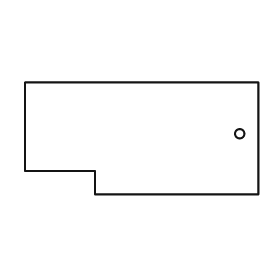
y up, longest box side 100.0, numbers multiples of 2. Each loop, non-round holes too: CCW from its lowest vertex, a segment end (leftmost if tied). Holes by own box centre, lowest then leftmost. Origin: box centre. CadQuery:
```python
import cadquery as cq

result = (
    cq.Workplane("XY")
    .moveTo(-20.0, -24.0)
    .lineTo(50.0, -24.0)
    .lineTo(50.0, 24.0)
    .lineTo(-50.0, 24.0)
    .lineTo(-50.0, -14.0)
    .lineTo(-20.0, -14.0)
    .close()
    .moveTo(42.0, 2.0)
    .circle(2.0)
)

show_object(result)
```